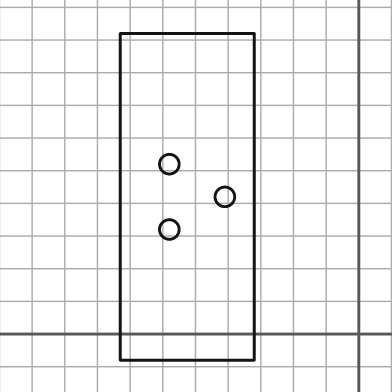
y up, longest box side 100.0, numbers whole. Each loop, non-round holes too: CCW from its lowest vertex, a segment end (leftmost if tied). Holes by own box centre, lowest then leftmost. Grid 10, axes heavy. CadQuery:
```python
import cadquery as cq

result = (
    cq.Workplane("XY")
    .moveTo(-73.0, -8.0)
    .lineTo(-32.0, -8.0)
    .lineTo(-32.0, 92.0)
    .lineTo(-73.0, 92.0)
    .close()
    .moveTo(-58.0, 32.0)
    .circle(3.0)
    .moveTo(-41.0, 42.0)
    .circle(3.0)
    .moveTo(-58.0, 52.0)
    .circle(3.0)
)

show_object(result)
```